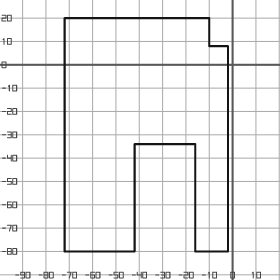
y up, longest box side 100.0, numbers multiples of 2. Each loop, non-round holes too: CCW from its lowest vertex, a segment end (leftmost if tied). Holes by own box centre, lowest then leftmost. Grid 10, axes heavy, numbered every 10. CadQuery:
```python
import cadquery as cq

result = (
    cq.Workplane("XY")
    .moveTo(-72.0, -80.0)
    .lineTo(-42.0, -80.0)
    .lineTo(-42.0, -34.0)
    .lineTo(-16.0, -34.0)
    .lineTo(-16.0, -80.0)
    .lineTo(-2.0, -80.0)
    .lineTo(-2.0, 8.0)
    .lineTo(-10.0, 8.0)
    .lineTo(-10.0, 20.0)
    .lineTo(-72.0, 20.0)
    .close()
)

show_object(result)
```